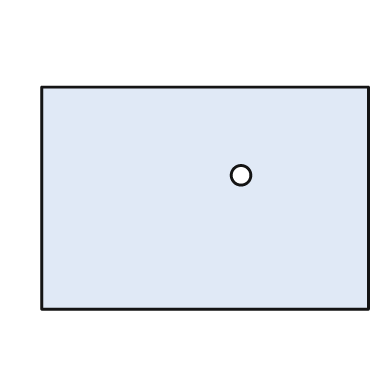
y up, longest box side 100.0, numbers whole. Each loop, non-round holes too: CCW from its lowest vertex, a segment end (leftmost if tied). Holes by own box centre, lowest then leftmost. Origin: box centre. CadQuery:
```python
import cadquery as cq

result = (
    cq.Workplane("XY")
    .moveTo(-50.0, -34.0)
    .lineTo(50.0, -34.0)
    .lineTo(50.0, 34.0)
    .lineTo(-50.0, 34.0)
    .close()
    .moveTo(11.0, 7.0)
    .circle(3.0)
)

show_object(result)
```